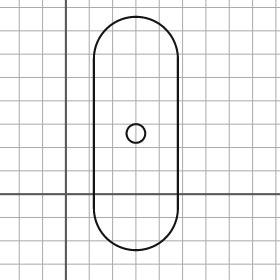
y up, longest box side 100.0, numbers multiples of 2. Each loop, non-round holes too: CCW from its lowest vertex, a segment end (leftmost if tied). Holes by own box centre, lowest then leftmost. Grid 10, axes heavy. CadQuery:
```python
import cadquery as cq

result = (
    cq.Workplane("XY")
    .moveTo(12.0, -6.0)
    .threePointArc((30.0, -24.0), (48.0, -6.0))
    .lineTo(48.0, 58.0)
    .threePointArc((30.0, 76.0), (12.0, 58.0))
    .close()
    .moveTo(30.0, 26.0)
    .circle(4.0)
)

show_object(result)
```